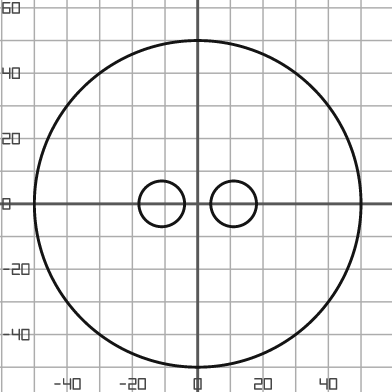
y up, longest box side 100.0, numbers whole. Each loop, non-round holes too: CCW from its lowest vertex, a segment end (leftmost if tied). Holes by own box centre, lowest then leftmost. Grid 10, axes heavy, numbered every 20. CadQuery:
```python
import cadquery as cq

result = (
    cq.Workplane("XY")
    .moveTo(0.0, 0.0)
    .circle(50.0)
    .moveTo(-11.0, 0.0)
    .circle(7.0)
    .moveTo(11.0, 0.0)
    .circle(7.0)
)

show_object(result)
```